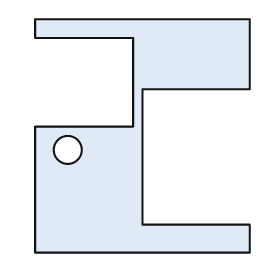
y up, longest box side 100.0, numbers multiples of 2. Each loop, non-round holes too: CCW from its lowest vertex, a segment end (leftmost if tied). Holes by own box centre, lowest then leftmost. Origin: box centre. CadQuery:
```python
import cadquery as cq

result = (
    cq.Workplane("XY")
    .moveTo(-46.0, -50.0)
    .lineTo(46.0, -50.0)
    .lineTo(46.0, -38.0)
    .lineTo(0.0, -38.0)
    .lineTo(0.0, 20.0)
    .lineTo(46.0, 20.0)
    .lineTo(46.0, 50.0)
    .lineTo(-46.0, 50.0)
    .lineTo(-46.0, 42.0)
    .lineTo(-4.0, 42.0)
    .lineTo(-4.0, 4.0)
    .lineTo(-46.0, 4.0)
    .close()
    .moveTo(-32.0, -6.0)
    .circle(6.0)
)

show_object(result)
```